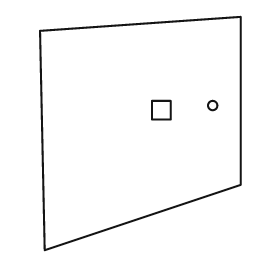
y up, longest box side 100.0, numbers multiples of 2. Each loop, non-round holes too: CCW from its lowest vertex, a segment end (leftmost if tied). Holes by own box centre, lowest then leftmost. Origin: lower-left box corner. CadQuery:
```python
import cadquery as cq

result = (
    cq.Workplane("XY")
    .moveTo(2.0, 0.0)
    .lineTo(86.0, 28.0)
    .lineTo(86.0, 100.0)
    .lineTo(0.0, 94.0)
    .close()
    .moveTo(48.0, 56.0)
    .lineTo(56.0, 56.0)
    .lineTo(56.0, 64.0)
    .lineTo(48.0, 64.0)
    .close()
    .moveTo(74.0, 62.0)
    .circle(2.0)
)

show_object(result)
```